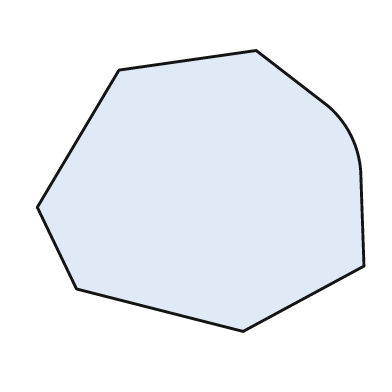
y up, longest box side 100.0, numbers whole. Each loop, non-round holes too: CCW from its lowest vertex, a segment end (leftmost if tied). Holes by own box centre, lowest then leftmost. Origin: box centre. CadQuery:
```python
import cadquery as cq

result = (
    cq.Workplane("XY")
    .moveTo(13.0, -43.0)
    .lineTo(50.0, -23.0)
    .lineTo(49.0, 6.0)
    .threePointArc((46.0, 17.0), (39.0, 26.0))
    .lineTo(17.0, 43.0)
    .lineTo(-25.0, 37.0)
    .lineTo(-50.0, -5.0)
    .lineTo(-38.0, -30.0)
    .close()
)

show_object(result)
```